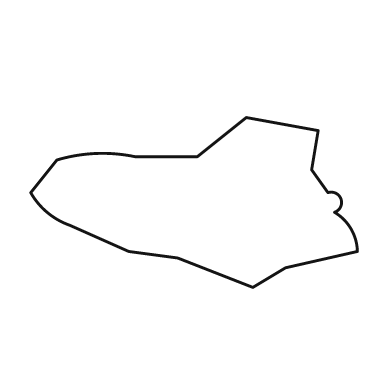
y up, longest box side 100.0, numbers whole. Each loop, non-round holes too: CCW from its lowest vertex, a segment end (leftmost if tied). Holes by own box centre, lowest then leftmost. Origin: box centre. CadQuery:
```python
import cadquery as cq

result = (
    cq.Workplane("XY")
    .moveTo(18.0, -26.0)
    .lineTo(28.0, -20.0)
    .lineTo(50.0, -15.0)
    .threePointArc((48.0, -8.0), (43.0, -3.0))
    .threePointArc((45.0, 1.0), (41.0, 3.0))
    .lineTo(36.0, 10.0)
    .lineTo(38.0, 22.0)
    .lineTo(16.0, 26.0)
    .lineTo(1.0, 14.0)
    .lineTo(-18.0, 14.0)
    .threePointArc((-30.0, 15.0), (-42.0, 13.0))
    .lineTo(-50.0, 3.0)
    .threePointArc((-45.0, -3.0), (-38.0, -7.0))
    .lineTo(-20.0, -15.0)
    .lineTo(-5.0, -17.0)
    .close()
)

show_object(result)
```